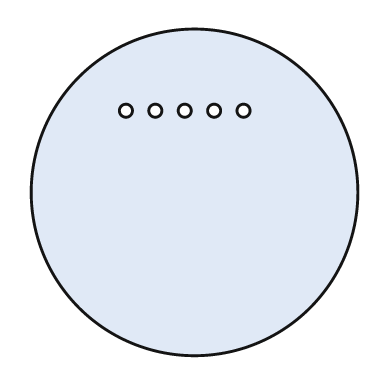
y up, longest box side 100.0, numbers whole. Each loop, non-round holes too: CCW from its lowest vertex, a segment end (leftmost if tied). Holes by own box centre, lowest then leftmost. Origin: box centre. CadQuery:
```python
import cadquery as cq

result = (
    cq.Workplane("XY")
    .moveTo(0.0, 0.0)
    .circle(50.0)
    .moveTo(-21.0, 25.0)
    .circle(2.0)
    .moveTo(-12.0, 25.0)
    .circle(2.0)
    .moveTo(-3.0, 25.0)
    .circle(2.0)
    .moveTo(6.0, 25.0)
    .circle(2.0)
    .moveTo(15.0, 25.0)
    .circle(2.0)
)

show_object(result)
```